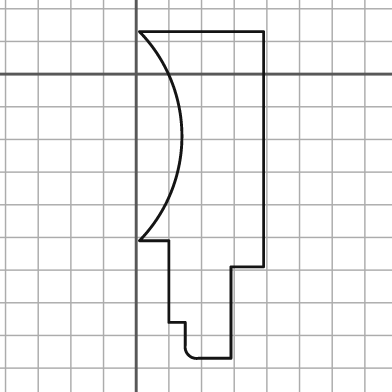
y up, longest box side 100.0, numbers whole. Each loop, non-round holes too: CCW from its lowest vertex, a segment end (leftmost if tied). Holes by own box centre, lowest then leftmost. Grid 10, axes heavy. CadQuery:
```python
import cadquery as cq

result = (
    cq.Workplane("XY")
    .moveTo(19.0, -87.0)
    .lineTo(29.0, -87.0)
    .lineTo(29.0, -59.0)
    .lineTo(39.0, -59.0)
    .lineTo(39.0, 13.0)
    .lineTo(1.0, 13.0)
    .threePointArc((14.0, -19.0), (1.0, -51.0))
    .lineTo(10.0, -51.0)
    .lineTo(10.0, -76.0)
    .lineTo(15.0, -76.0)
    .lineTo(15.0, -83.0)
    .threePointArc((16.0, -86.0), (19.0, -87.0))
    .close()
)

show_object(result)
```